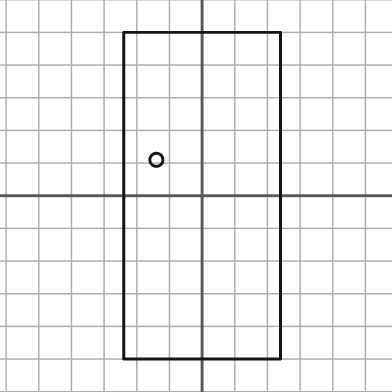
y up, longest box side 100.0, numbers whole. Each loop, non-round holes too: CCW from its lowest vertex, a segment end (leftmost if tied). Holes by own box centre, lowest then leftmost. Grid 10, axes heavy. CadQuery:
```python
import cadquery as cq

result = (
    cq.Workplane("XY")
    .moveTo(-24.0, -50.0)
    .lineTo(24.0, -50.0)
    .lineTo(24.0, 50.0)
    .lineTo(-24.0, 50.0)
    .close()
    .moveTo(-14.0, 11.0)
    .circle(2.0)
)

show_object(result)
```